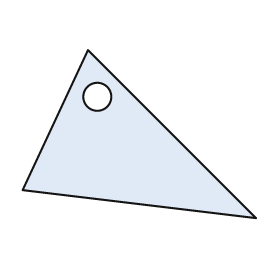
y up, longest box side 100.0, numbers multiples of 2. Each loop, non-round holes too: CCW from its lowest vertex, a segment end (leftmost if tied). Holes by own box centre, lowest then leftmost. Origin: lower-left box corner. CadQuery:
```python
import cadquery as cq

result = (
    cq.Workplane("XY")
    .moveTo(100.0, 0.0)
    .lineTo(28.0, 72.0)
    .lineTo(0.0, 12.0)
    .close()
    .moveTo(32.0, 52.0)
    .circle(6.0)
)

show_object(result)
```